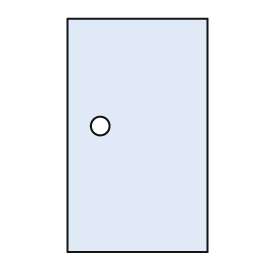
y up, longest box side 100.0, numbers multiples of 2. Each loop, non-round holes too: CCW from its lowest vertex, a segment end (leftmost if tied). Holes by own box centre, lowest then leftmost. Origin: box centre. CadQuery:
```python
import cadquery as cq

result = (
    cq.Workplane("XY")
    .moveTo(-30.0, -50.0)
    .lineTo(30.0, -50.0)
    .lineTo(30.0, 50.0)
    .lineTo(-30.0, 50.0)
    .close()
    .moveTo(-16.0, 4.0)
    .circle(4.0)
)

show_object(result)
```